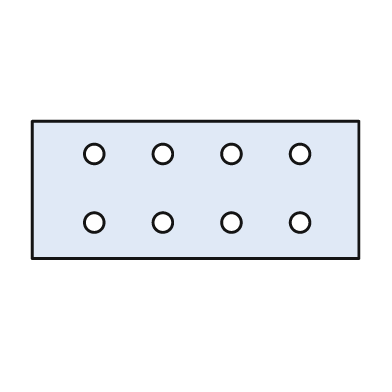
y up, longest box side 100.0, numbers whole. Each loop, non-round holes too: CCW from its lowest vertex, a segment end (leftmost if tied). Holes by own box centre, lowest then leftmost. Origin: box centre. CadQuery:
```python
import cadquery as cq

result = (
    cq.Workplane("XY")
    .moveTo(-50.0, -21.0)
    .lineTo(50.0, -21.0)
    .lineTo(50.0, 21.0)
    .lineTo(-50.0, 21.0)
    .close()
    .moveTo(-31.0, -10.0)
    .circle(3.0)
    .moveTo(-10.0, -10.0)
    .circle(3.0)
    .moveTo(11.0, -10.0)
    .circle(3.0)
    .moveTo(32.0, -10.0)
    .circle(3.0)
    .moveTo(-31.0, 11.0)
    .circle(3.0)
    .moveTo(-10.0, 11.0)
    .circle(3.0)
    .moveTo(11.0, 11.0)
    .circle(3.0)
    .moveTo(32.0, 11.0)
    .circle(3.0)
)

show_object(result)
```